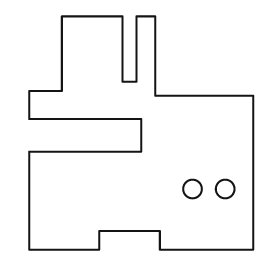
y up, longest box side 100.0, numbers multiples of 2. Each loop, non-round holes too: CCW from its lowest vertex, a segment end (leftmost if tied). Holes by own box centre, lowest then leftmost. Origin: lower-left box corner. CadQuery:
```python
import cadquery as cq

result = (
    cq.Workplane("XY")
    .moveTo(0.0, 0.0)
    .lineTo(30.0, 0.0)
    .lineTo(30.0, 8.0)
    .lineTo(56.0, 8.0)
    .lineTo(56.0, 0.0)
    .lineTo(96.0, 0.0)
    .lineTo(96.0, 66.0)
    .lineTo(54.0, 66.0)
    .lineTo(54.0, 100.0)
    .lineTo(46.0, 100.0)
    .lineTo(46.0, 72.0)
    .lineTo(40.0, 72.0)
    .lineTo(40.0, 100.0)
    .lineTo(14.0, 100.0)
    .lineTo(14.0, 68.0)
    .lineTo(0.0, 68.0)
    .lineTo(0.0, 56.0)
    .lineTo(48.0, 56.0)
    .lineTo(48.0, 42.0)
    .lineTo(0.0, 42.0)
    .close()
    .moveTo(70.0, 26.0)
    .circle(4.0)
    .moveTo(84.0, 26.0)
    .circle(4.0)
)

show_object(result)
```